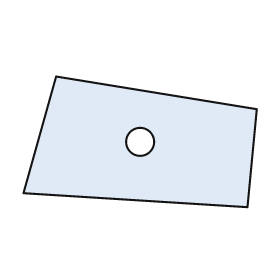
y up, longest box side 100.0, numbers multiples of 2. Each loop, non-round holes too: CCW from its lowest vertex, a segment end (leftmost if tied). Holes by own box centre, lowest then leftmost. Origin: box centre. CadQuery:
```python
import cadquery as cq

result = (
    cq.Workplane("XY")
    .moveTo(46.0, -28.0)
    .lineTo(50.0, 14.0)
    .lineTo(-36.0, 28.0)
    .lineTo(-50.0, -22.0)
    .close()
    .moveTo(0.0, 0.0)
    .circle(6.0)
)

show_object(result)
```